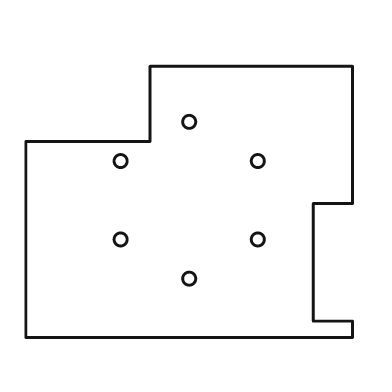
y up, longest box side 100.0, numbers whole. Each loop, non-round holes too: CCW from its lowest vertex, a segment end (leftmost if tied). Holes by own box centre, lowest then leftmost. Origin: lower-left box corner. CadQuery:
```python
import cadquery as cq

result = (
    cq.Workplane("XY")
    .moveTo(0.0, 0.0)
    .lineTo(100.0, 0.0)
    .lineTo(100.0, 5.0)
    .lineTo(88.0, 5.0)
    .lineTo(88.0, 41.0)
    .lineTo(100.0, 41.0)
    .lineTo(100.0, 83.0)
    .lineTo(38.0, 83.0)
    .lineTo(38.0, 60.0)
    .lineTo(0.0, 60.0)
    .close()
    .moveTo(50.0, 18.0)
    .circle(2.0)
    .moveTo(29.0, 30.0)
    .circle(2.0)
    .moveTo(71.0, 30.0)
    .circle(2.0)
    .moveTo(29.0, 54.0)
    .circle(2.0)
    .moveTo(71.0, 54.0)
    .circle(2.0)
    .moveTo(50.0, 66.0)
    .circle(2.0)
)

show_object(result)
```